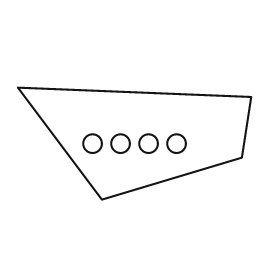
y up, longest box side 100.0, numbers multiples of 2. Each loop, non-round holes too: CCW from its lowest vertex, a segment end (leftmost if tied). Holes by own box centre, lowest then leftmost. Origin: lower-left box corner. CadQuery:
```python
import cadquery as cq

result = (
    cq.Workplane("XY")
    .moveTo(36.0, 0.0)
    .lineTo(96.0, 18.0)
    .lineTo(100.0, 44.0)
    .lineTo(0.0, 48.0)
    .close()
    .moveTo(32.0, 24.0)
    .circle(4.0)
    .moveTo(44.0, 24.0)
    .circle(4.0)
    .moveTo(56.0, 24.0)
    .circle(4.0)
    .moveTo(68.0, 24.0)
    .circle(4.0)
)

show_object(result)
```